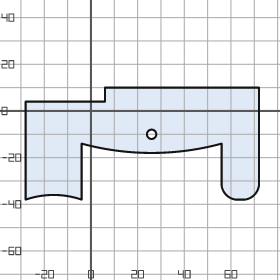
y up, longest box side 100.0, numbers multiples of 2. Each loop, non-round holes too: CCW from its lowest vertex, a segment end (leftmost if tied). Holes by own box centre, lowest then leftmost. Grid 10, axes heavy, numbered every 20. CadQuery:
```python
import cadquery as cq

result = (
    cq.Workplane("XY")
    .moveTo(-28.0, -38.0)
    .threePointArc((-16.0, -36.0), (-4.0, -38.0))
    .lineTo(-4.0, -14.0)
    .threePointArc((26.0, -18.0), (56.0, -14.0))
    .lineTo(56.0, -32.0)
    .threePointArc((58.0, -36.0), (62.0, -38.0))
    .lineTo(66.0, -38.0)
    .threePointArc((70.0, -36.0), (72.0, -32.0))
    .lineTo(72.0, 10.0)
    .lineTo(6.0, 10.0)
    .lineTo(6.0, 4.0)
    .lineTo(-28.0, 4.0)
    .close()
    .moveTo(26.0, -10.0)
    .circle(2.0)
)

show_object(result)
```